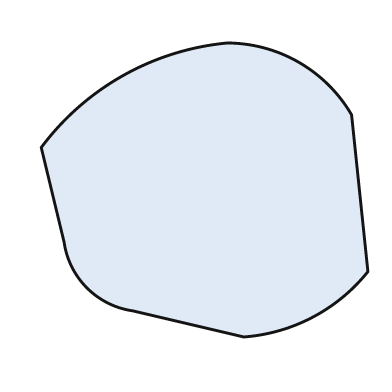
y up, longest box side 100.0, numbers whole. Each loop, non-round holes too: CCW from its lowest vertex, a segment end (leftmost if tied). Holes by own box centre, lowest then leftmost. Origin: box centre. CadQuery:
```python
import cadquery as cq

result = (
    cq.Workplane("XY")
    .moveTo(12.0, -45.0)
    .threePointArc((33.0, -39.0), (50.0, -25.0))
    .lineTo(45.0, 23.0)
    .threePointArc((29.0, 39.0), (7.0, 45.0))
    .threePointArc((-25.0, 35.0), (-50.0, 13.0))
    .lineTo(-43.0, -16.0)
    .threePointArc((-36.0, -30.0), (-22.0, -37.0))
    .close()
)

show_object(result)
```